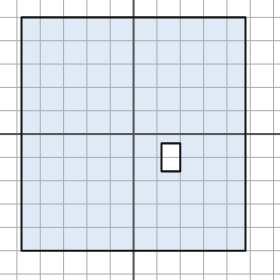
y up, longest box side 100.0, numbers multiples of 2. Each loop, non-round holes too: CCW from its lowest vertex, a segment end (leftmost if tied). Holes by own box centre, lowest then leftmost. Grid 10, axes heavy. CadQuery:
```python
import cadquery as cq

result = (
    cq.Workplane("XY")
    .moveTo(-48.0, -50.0)
    .lineTo(48.0, -50.0)
    .lineTo(48.0, 50.0)
    .lineTo(-48.0, 50.0)
    .close()
    .moveTo(12.0, -16.0)
    .lineTo(20.0, -16.0)
    .lineTo(20.0, -4.0)
    .lineTo(12.0, -4.0)
    .close()
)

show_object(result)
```